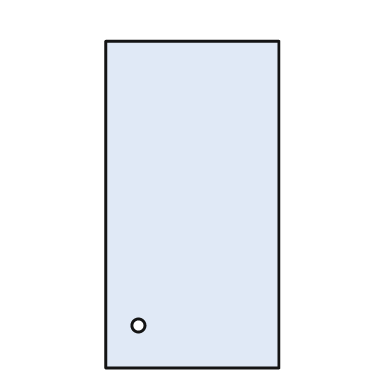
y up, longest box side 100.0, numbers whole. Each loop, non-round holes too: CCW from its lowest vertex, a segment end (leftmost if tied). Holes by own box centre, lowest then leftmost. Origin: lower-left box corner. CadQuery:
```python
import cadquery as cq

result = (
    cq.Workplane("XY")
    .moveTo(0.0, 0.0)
    .lineTo(53.0, 0.0)
    .lineTo(53.0, 100.0)
    .lineTo(0.0, 100.0)
    .close()
    .moveTo(10.0, 13.0)
    .circle(2.0)
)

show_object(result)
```